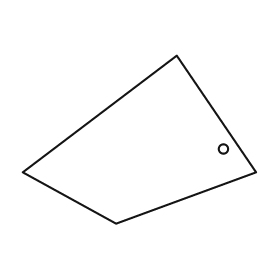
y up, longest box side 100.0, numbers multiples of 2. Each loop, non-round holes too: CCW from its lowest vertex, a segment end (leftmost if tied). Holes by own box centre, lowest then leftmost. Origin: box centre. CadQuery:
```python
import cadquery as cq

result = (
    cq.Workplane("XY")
    .moveTo(-10.0, -36.0)
    .lineTo(50.0, -14.0)
    .lineTo(16.0, 36.0)
    .lineTo(-50.0, -14.0)
    .close()
    .moveTo(36.0, -4.0)
    .circle(2.0)
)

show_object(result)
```